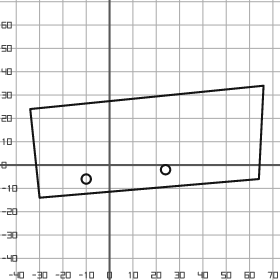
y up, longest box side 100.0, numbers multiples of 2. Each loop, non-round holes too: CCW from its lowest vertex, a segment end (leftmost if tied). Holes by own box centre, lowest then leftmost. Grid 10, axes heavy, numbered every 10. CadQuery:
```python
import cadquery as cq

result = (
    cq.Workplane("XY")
    .moveTo(-30.0, -14.0)
    .lineTo(64.0, -6.0)
    .lineTo(66.0, 34.0)
    .lineTo(-34.0, 24.0)
    .close()
    .moveTo(-10.0, -6.0)
    .circle(2.0)
    .moveTo(24.0, -2.0)
    .circle(2.0)
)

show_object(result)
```